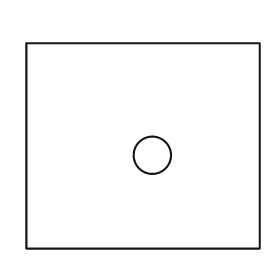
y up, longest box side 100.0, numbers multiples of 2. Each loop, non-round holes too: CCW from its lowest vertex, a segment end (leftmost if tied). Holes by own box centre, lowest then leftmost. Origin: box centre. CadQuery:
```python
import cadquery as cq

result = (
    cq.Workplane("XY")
    .moveTo(-50.0, -44.0)
    .lineTo(50.0, -44.0)
    .lineTo(50.0, 44.0)
    .lineTo(-50.0, 44.0)
    .close()
    .moveTo(4.0, -4.0)
    .circle(8.0)
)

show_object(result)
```